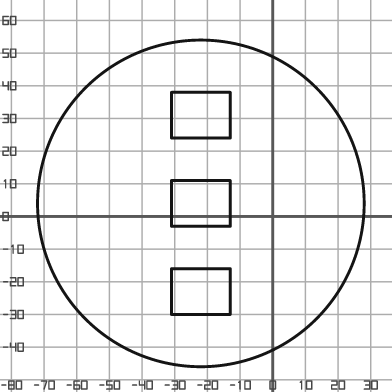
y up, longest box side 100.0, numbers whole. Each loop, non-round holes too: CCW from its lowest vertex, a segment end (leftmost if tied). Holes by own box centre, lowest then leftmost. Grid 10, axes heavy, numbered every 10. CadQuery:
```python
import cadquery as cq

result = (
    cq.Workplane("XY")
    .moveTo(-22.0, 4.0)
    .circle(50.0)
    .moveTo(-31.0, -30.0)
    .lineTo(-13.0, -30.0)
    .lineTo(-13.0, -16.0)
    .lineTo(-31.0, -16.0)
    .close()
    .moveTo(-31.0, -3.0)
    .lineTo(-13.0, -3.0)
    .lineTo(-13.0, 11.0)
    .lineTo(-31.0, 11.0)
    .close()
    .moveTo(-31.0, 24.0)
    .lineTo(-13.0, 24.0)
    .lineTo(-13.0, 38.0)
    .lineTo(-31.0, 38.0)
    .close()
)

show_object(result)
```